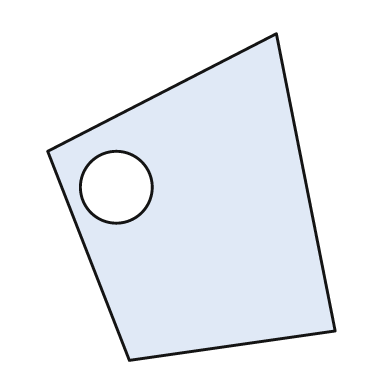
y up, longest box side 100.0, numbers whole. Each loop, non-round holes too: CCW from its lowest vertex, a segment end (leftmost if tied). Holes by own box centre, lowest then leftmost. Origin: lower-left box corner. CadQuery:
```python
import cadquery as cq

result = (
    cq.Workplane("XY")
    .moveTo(25.0, 0.0)
    .lineTo(88.0, 9.0)
    .lineTo(70.0, 100.0)
    .lineTo(0.0, 64.0)
    .close()
    .moveTo(21.0, 53.0)
    .circle(11.0)
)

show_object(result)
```